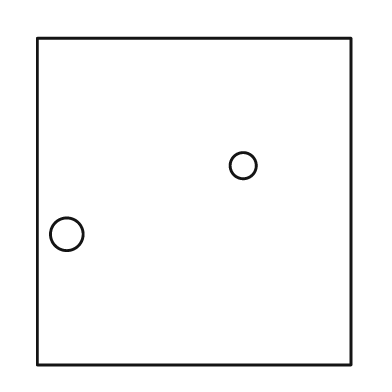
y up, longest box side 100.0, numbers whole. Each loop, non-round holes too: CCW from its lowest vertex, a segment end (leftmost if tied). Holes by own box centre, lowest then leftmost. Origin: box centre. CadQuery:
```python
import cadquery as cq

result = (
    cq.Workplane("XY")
    .moveTo(-48.0, -50.0)
    .lineTo(48.0, -50.0)
    .lineTo(48.0, 50.0)
    .lineTo(-48.0, 50.0)
    .close()
    .moveTo(-39.0, -10.0)
    .circle(5.0)
    .moveTo(15.0, 11.0)
    .circle(4.0)
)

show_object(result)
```